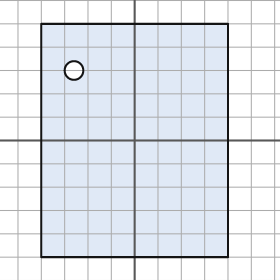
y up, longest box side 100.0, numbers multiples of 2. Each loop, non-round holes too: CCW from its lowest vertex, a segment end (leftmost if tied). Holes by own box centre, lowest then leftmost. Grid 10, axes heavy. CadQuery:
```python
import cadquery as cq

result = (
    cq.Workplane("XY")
    .moveTo(-40.0, -50.0)
    .lineTo(40.0, -50.0)
    .lineTo(40.0, 50.0)
    .lineTo(-40.0, 50.0)
    .close()
    .moveTo(-26.0, 30.0)
    .circle(4.0)
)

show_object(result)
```